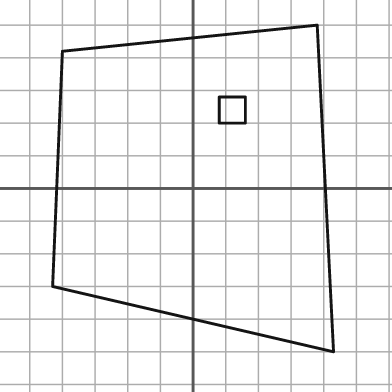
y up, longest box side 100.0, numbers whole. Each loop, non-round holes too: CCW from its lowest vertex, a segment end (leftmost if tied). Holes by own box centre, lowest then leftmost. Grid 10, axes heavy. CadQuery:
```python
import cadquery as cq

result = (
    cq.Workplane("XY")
    .moveTo(43.0, -50.0)
    .lineTo(38.0, 50.0)
    .lineTo(-40.0, 42.0)
    .lineTo(-43.0, -30.0)
    .close()
    .moveTo(8.0, 20.0)
    .lineTo(16.0, 20.0)
    .lineTo(16.0, 28.0)
    .lineTo(8.0, 28.0)
    .close()
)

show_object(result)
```